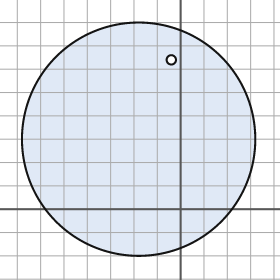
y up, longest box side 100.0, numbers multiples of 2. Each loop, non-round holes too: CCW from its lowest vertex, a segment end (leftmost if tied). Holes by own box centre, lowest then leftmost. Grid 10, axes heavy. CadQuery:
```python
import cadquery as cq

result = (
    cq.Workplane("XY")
    .moveTo(-18.0, 30.0)
    .circle(50.0)
    .moveTo(-4.0, 64.0)
    .circle(2.0)
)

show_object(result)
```